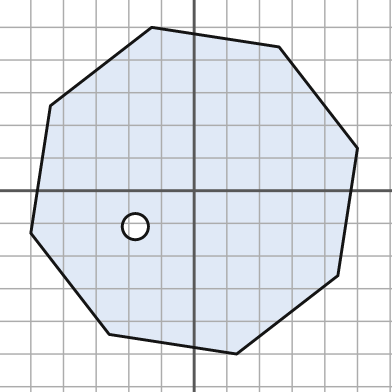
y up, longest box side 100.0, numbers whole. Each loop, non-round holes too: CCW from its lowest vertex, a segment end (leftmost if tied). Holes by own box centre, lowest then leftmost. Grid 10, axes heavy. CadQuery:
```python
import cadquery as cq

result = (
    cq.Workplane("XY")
    .moveTo(13.0, -50.0)
    .lineTo(44.0, -26.0)
    .lineTo(50.0, 13.0)
    .lineTo(26.0, 44.0)
    .lineTo(-13.0, 50.0)
    .lineTo(-44.0, 26.0)
    .lineTo(-50.0, -13.0)
    .lineTo(-26.0, -44.0)
    .close()
    .moveTo(-18.0, -11.0)
    .circle(4.0)
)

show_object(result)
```